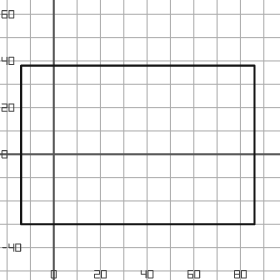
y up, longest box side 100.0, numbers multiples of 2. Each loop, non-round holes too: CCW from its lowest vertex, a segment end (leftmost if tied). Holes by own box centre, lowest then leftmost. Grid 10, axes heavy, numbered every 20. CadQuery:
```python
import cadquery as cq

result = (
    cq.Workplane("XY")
    .moveTo(-14.0, -30.0)
    .lineTo(86.0, -30.0)
    .lineTo(86.0, 38.0)
    .lineTo(-14.0, 38.0)
    .close()
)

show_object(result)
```